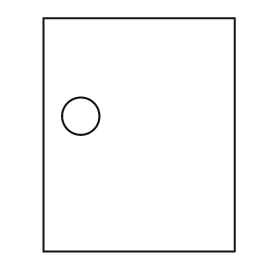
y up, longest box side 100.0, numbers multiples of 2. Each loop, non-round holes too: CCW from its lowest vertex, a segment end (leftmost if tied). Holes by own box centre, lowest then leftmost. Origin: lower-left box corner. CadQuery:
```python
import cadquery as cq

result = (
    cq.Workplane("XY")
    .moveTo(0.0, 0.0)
    .lineTo(82.0, 0.0)
    .lineTo(82.0, 100.0)
    .lineTo(0.0, 100.0)
    .close()
    .moveTo(16.0, 58.0)
    .circle(8.0)
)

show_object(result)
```